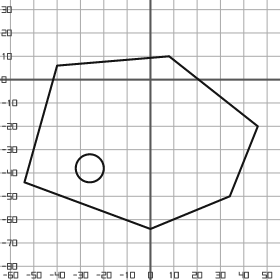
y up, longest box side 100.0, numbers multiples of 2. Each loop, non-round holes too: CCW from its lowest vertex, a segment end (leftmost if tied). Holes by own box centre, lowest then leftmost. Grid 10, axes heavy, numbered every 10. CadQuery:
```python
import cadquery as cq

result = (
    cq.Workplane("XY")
    .moveTo(0.0, -64.0)
    .lineTo(34.0, -50.0)
    .lineTo(46.0, -20.0)
    .lineTo(8.0, 10.0)
    .lineTo(-40.0, 6.0)
    .lineTo(-54.0, -44.0)
    .close()
    .moveTo(-26.0, -38.0)
    .circle(6.0)
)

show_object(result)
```